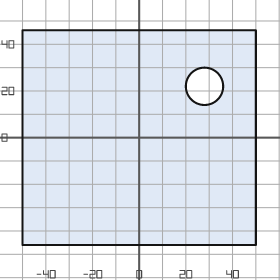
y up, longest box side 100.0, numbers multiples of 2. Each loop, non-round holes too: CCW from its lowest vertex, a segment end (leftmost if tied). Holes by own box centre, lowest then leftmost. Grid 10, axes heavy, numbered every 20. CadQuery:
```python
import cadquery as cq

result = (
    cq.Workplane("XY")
    .moveTo(-50.0, -46.0)
    .lineTo(50.0, -46.0)
    .lineTo(50.0, 46.0)
    .lineTo(-50.0, 46.0)
    .close()
    .moveTo(28.0, 22.0)
    .circle(8.0)
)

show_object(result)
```